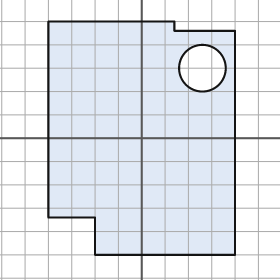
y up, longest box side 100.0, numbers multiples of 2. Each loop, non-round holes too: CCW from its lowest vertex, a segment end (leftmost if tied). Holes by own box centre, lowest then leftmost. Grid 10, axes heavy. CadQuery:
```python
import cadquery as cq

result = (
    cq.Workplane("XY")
    .moveTo(-20.0, -50.0)
    .lineTo(40.0, -50.0)
    .lineTo(40.0, 46.0)
    .lineTo(14.0, 46.0)
    .lineTo(14.0, 50.0)
    .lineTo(-40.0, 50.0)
    .lineTo(-40.0, -34.0)
    .lineTo(-20.0, -34.0)
    .close()
    .moveTo(26.0, 30.0)
    .circle(10.0)
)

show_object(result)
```